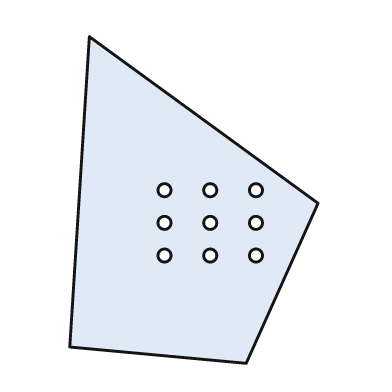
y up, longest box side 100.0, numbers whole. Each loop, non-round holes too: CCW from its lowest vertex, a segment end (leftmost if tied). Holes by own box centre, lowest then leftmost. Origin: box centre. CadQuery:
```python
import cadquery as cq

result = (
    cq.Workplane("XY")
    .moveTo(16.0, -50.0)
    .lineTo(38.0, -1.0)
    .lineTo(-32.0, 50.0)
    .lineTo(-38.0, -45.0)
    .close()
    .moveTo(-9.0, -17.0)
    .circle(2.0)
    .moveTo(5.0, -17.0)
    .circle(2.0)
    .moveTo(19.0, -17.0)
    .circle(2.0)
    .moveTo(-9.0, -7.0)
    .circle(2.0)
    .moveTo(5.0, -7.0)
    .circle(2.0)
    .moveTo(19.0, -7.0)
    .circle(2.0)
    .moveTo(-9.0, 3.0)
    .circle(2.0)
    .moveTo(5.0, 3.0)
    .circle(2.0)
    .moveTo(19.0, 3.0)
    .circle(2.0)
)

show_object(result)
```